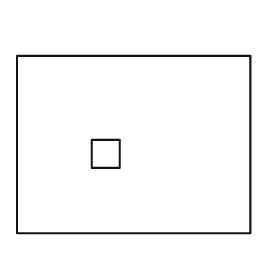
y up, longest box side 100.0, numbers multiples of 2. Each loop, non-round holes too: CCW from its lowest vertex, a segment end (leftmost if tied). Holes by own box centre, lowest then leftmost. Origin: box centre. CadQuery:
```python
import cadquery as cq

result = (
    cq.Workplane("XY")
    .moveTo(-50.0, -38.0)
    .lineTo(50.0, -38.0)
    .lineTo(50.0, 38.0)
    .lineTo(-50.0, 38.0)
    .close()
    .moveTo(-18.0, -10.0)
    .lineTo(-6.0, -10.0)
    .lineTo(-6.0, 2.0)
    .lineTo(-18.0, 2.0)
    .close()
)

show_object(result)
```